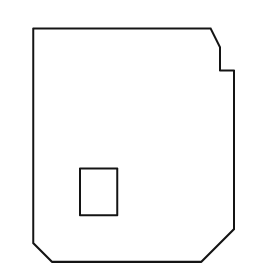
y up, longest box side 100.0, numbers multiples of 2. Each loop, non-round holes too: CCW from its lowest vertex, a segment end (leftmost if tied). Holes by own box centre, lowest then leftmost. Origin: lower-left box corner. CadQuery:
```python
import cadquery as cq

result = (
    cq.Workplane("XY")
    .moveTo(8.0, 0.0)
    .lineTo(72.0, 0.0)
    .lineTo(86.0, 14.0)
    .lineTo(86.0, 82.0)
    .lineTo(80.0, 82.0)
    .lineTo(80.0, 92.0)
    .lineTo(76.0, 100.0)
    .lineTo(0.0, 100.0)
    .lineTo(0.0, 8.0)
    .close()
    .moveTo(20.0, 20.0)
    .lineTo(36.0, 20.0)
    .lineTo(36.0, 40.0)
    .lineTo(20.0, 40.0)
    .close()
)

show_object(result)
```